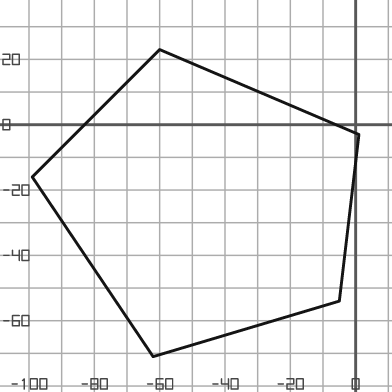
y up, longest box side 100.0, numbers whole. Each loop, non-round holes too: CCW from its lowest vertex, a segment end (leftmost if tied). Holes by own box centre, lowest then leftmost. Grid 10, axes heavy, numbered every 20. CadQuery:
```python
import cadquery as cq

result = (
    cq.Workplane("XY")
    .moveTo(-62.0, -71.0)
    .lineTo(-5.0, -54.0)
    .lineTo(1.0, -3.0)
    .lineTo(-60.0, 23.0)
    .lineTo(-99.0, -16.0)
    .close()
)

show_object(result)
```